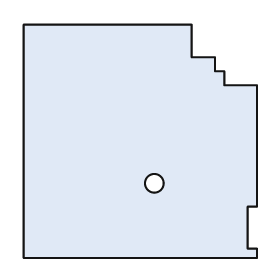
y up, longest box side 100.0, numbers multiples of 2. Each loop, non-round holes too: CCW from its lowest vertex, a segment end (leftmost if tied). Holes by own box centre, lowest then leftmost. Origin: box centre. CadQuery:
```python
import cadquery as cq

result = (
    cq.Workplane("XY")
    .moveTo(-50.0, -50.0)
    .lineTo(50.0, -50.0)
    .lineTo(50.0, -46.0)
    .lineTo(46.0, -46.0)
    .lineTo(46.0, -28.0)
    .lineTo(50.0, -28.0)
    .lineTo(50.0, 24.0)
    .lineTo(36.0, 24.0)
    .lineTo(36.0, 30.0)
    .lineTo(32.0, 30.0)
    .lineTo(32.0, 36.0)
    .lineTo(22.0, 36.0)
    .lineTo(22.0, 50.0)
    .lineTo(-50.0, 50.0)
    .close()
    .moveTo(6.0, -18.0)
    .circle(4.0)
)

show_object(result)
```